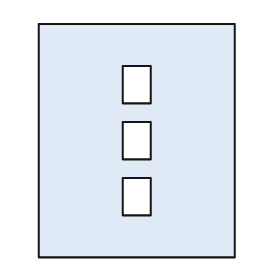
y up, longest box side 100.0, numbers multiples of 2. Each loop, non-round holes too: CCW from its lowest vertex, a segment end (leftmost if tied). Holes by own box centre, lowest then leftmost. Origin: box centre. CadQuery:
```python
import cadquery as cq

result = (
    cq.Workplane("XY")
    .moveTo(-42.0, -50.0)
    .lineTo(42.0, -50.0)
    .lineTo(42.0, 50.0)
    .lineTo(-42.0, 50.0)
    .close()
    .moveTo(-6.0, -32.0)
    .lineTo(6.0, -32.0)
    .lineTo(6.0, -16.0)
    .lineTo(-6.0, -16.0)
    .close()
    .moveTo(-6.0, -8.0)
    .lineTo(6.0, -8.0)
    .lineTo(6.0, 8.0)
    .lineTo(-6.0, 8.0)
    .close()
    .moveTo(-6.0, 16.0)
    .lineTo(6.0, 16.0)
    .lineTo(6.0, 32.0)
    .lineTo(-6.0, 32.0)
    .close()
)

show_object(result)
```